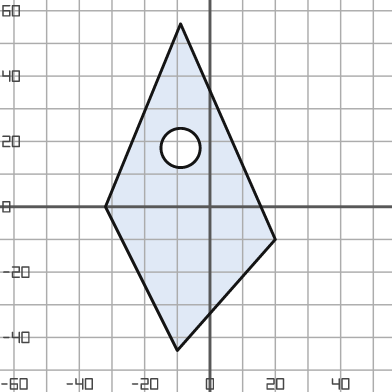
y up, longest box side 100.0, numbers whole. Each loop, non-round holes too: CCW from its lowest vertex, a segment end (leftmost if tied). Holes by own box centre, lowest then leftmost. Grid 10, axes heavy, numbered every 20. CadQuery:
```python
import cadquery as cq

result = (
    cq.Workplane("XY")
    .moveTo(-10.0, -44.0)
    .lineTo(20.0, -10.0)
    .lineTo(-9.0, 56.0)
    .lineTo(-32.0, 0.0)
    .close()
    .moveTo(-9.0, 18.0)
    .circle(6.0)
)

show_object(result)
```